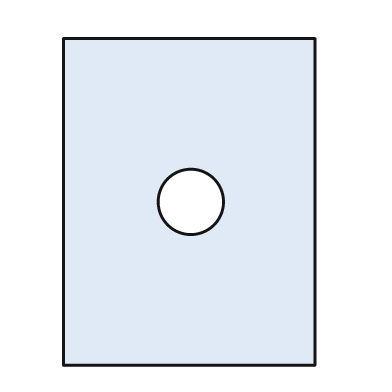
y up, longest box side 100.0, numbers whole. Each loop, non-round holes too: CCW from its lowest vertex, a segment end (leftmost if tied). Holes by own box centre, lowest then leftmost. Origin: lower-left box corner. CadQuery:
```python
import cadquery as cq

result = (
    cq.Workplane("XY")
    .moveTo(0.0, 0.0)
    .lineTo(77.0, 0.0)
    .lineTo(77.0, 100.0)
    .lineTo(0.0, 100.0)
    .close()
    .moveTo(39.0, 50.0)
    .circle(10.0)
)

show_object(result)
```